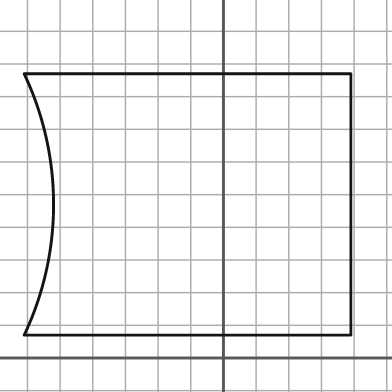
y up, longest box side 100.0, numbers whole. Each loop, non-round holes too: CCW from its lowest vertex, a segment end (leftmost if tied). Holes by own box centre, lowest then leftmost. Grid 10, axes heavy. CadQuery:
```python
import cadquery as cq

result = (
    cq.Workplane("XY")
    .moveTo(-61.0, 7.0)
    .lineTo(39.0, 7.0)
    .lineTo(39.0, 87.0)
    .lineTo(-61.0, 87.0)
    .threePointArc((-52.0, 47.0), (-61.0, 7.0))
    .close()
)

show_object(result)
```